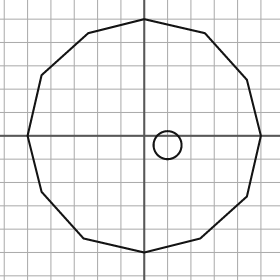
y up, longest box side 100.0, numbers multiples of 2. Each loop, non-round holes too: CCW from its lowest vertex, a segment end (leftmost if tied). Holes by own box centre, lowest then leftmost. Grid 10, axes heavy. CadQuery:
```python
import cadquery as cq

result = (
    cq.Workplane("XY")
    .moveTo(0.0, -50.0)
    .lineTo(24.0, -44.0)
    .lineTo(44.0, -26.0)
    .lineTo(50.0, 0.0)
    .lineTo(44.0, 24.0)
    .lineTo(26.0, 44.0)
    .lineTo(0.0, 50.0)
    .lineTo(-24.0, 44.0)
    .lineTo(-44.0, 26.0)
    .lineTo(-50.0, 0.0)
    .lineTo(-44.0, -24.0)
    .lineTo(-26.0, -44.0)
    .close()
    .moveTo(10.0, -4.0)
    .circle(6.0)
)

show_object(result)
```